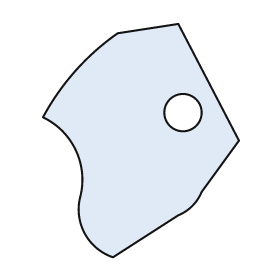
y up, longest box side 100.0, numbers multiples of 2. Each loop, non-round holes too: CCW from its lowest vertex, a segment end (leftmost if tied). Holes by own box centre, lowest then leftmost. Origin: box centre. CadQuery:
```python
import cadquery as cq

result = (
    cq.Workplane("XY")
    .moveTo(-12.0, -50.0)
    .lineTo(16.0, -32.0)
    .threePointArc((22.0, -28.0), (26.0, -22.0))
    .lineTo(42.0, 0.0)
    .lineTo(16.0, 50.0)
    .lineTo(-10.0, 46.0)
    .threePointArc((-28.0, 30.0), (-42.0, 10.0))
    .threePointArc((-28.0, -4.0), (-26.0, -24.0))
    .threePointArc((-24.0, -40.0), (-12.0, -50.0))
    .close()
    .moveTo(18.0, 12.0)
    .circle(8.0)
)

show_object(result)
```